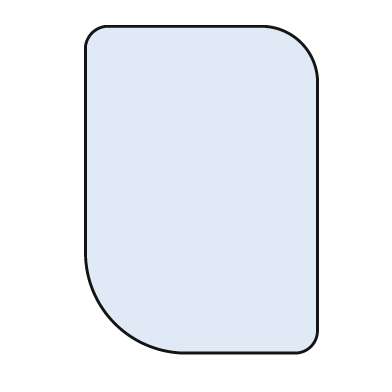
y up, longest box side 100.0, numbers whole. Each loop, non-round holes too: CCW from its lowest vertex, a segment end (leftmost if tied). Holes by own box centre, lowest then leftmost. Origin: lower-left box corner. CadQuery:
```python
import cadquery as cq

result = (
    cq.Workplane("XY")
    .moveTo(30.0, 0.0)
    .lineTo(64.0, 0.0)
    .threePointArc((69.0, 2.0), (71.0, 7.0))
    .lineTo(71.0, 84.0)
    .threePointArc((66.0, 95.0), (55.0, 100.0))
    .lineTo(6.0, 100.0)
    .threePointArc((2.0, 98.0), (0.0, 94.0))
    .lineTo(0.0, 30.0)
    .threePointArc((9.0, 9.0), (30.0, 0.0))
    .close()
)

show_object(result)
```